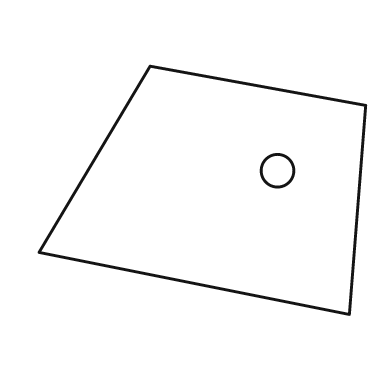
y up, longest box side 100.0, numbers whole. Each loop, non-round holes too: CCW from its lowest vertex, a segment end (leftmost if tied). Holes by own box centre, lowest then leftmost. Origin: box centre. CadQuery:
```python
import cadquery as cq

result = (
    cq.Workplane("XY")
    .moveTo(45.0, -38.0)
    .lineTo(50.0, 26.0)
    .lineTo(-16.0, 38.0)
    .lineTo(-50.0, -19.0)
    .close()
    .moveTo(23.0, 6.0)
    .circle(5.0)
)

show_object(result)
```